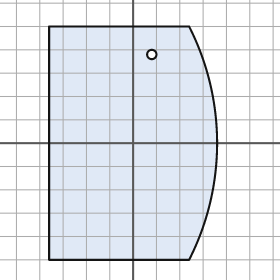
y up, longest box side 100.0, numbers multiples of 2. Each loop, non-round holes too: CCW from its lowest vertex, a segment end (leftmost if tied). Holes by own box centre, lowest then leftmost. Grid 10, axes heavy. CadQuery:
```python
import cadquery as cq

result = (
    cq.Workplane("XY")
    .moveTo(-36.0, -50.0)
    .lineTo(24.0, -50.0)
    .threePointArc((36.0, 0.0), (24.0, 50.0))
    .lineTo(-36.0, 50.0)
    .close()
    .moveTo(8.0, 38.0)
    .circle(2.0)
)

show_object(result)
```